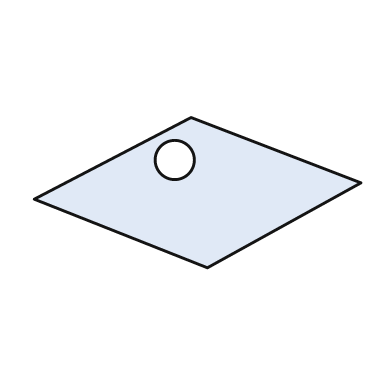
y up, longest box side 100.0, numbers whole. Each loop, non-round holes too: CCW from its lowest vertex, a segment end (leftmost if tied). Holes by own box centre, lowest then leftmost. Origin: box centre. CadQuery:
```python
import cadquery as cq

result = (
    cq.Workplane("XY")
    .moveTo(3.0, -23.0)
    .lineTo(50.0, 3.0)
    .lineTo(-2.0, 23.0)
    .lineTo(-50.0, -2.0)
    .close()
    .moveTo(-7.0, 10.0)
    .circle(6.0)
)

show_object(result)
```